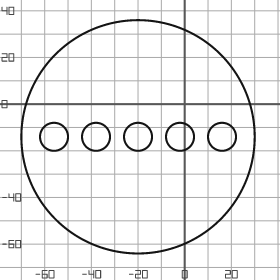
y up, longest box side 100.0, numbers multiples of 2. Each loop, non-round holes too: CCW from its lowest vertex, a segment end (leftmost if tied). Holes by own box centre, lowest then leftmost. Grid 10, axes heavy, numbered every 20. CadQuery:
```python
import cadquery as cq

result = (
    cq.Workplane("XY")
    .moveTo(-20.0, -14.0)
    .circle(50.0)
    .moveTo(-56.0, -14.0)
    .circle(6.0)
    .moveTo(-38.0, -14.0)
    .circle(6.0)
    .moveTo(-20.0, -14.0)
    .circle(6.0)
    .moveTo(-2.0, -14.0)
    .circle(6.0)
    .moveTo(16.0, -14.0)
    .circle(6.0)
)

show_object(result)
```